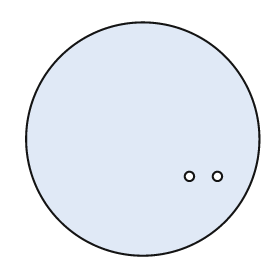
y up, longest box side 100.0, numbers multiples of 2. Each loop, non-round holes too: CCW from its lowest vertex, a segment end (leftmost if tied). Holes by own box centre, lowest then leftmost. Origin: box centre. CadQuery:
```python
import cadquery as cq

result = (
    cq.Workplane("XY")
    .moveTo(0.0, 0.0)
    .circle(50.0)
    .moveTo(20.0, -16.0)
    .circle(2.0)
    .moveTo(32.0, -16.0)
    .circle(2.0)
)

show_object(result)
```